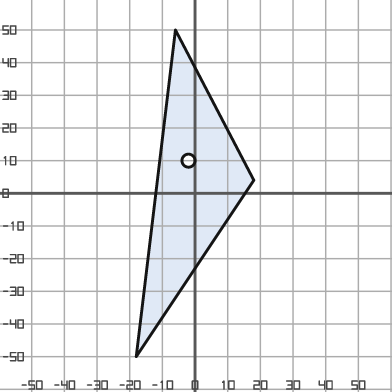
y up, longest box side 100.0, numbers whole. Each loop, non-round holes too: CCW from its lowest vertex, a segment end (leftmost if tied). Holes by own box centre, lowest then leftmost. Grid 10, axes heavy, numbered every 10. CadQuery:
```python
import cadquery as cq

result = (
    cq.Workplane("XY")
    .moveTo(-18.0, -50.0)
    .lineTo(18.0, 4.0)
    .lineTo(-6.0, 50.0)
    .close()
    .moveTo(-2.0, 10.0)
    .circle(2.0)
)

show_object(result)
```